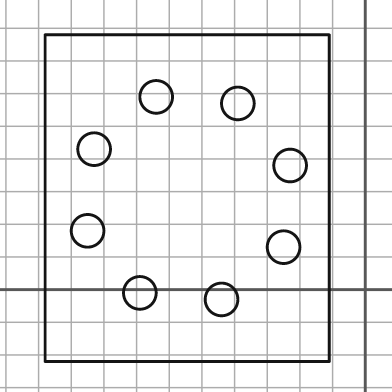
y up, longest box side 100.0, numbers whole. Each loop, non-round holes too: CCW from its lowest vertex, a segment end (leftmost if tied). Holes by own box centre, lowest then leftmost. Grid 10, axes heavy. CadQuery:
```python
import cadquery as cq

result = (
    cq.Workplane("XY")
    .moveTo(-98.0, -22.0)
    .lineTo(-11.0, -22.0)
    .lineTo(-11.0, 78.0)
    .lineTo(-98.0, 78.0)
    .close()
    .moveTo(-44.0, -3.0)
    .circle(5.0)
    .moveTo(-69.0, -1.0)
    .circle(5.0)
    .moveTo(-25.0, 13.0)
    .circle(5.0)
    .moveTo(-85.0, 18.0)
    .circle(5.0)
    .moveTo(-23.0, 38.0)
    .circle(5.0)
    .moveTo(-83.0, 43.0)
    .circle(5.0)
    .moveTo(-39.0, 57.0)
    .circle(5.0)
    .moveTo(-64.0, 59.0)
    .circle(5.0)
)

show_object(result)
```